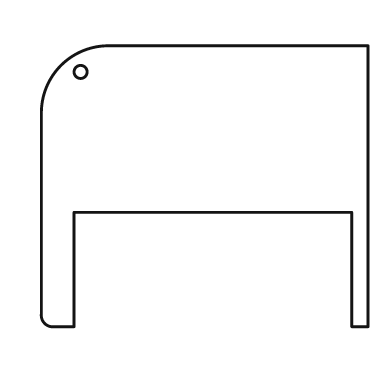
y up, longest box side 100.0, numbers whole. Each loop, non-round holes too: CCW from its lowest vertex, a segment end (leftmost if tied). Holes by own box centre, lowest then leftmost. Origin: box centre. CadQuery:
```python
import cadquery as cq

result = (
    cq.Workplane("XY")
    .moveTo(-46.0, -43.0)
    .lineTo(-40.0, -43.0)
    .lineTo(-40.0, -8.0)
    .lineTo(45.0, -8.0)
    .lineTo(45.0, -43.0)
    .lineTo(50.0, -43.0)
    .lineTo(50.0, 43.0)
    .lineTo(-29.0, 43.0)
    .threePointArc((-44.0, 37.0), (-50.0, 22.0))
    .lineTo(-50.0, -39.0)
    .threePointArc((-49.0, -42.0), (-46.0, -43.0))
    .close()
    .moveTo(-38.0, 35.0)
    .circle(2.0)
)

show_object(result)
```